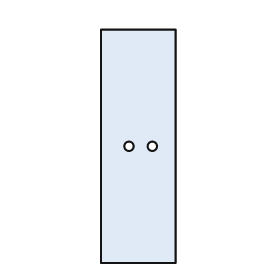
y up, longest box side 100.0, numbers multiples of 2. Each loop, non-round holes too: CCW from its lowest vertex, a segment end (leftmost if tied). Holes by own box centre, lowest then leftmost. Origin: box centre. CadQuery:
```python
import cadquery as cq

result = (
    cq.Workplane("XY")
    .moveTo(-16.0, -50.0)
    .lineTo(16.0, -50.0)
    .lineTo(16.0, 50.0)
    .lineTo(-16.0, 50.0)
    .close()
    .moveTo(-4.0, 0.0)
    .circle(2.0)
    .moveTo(6.0, 0.0)
    .circle(2.0)
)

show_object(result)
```